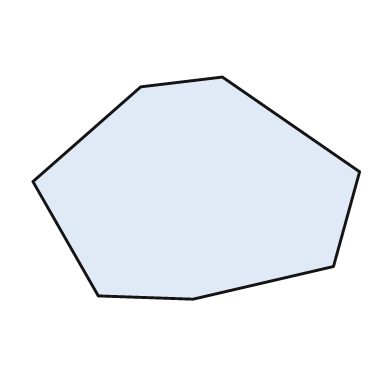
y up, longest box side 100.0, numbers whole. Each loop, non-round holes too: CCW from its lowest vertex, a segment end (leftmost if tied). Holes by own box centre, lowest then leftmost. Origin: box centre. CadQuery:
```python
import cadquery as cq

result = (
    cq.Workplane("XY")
    .moveTo(-1.0, -34.0)
    .lineTo(42.0, -24.0)
    .lineTo(50.0, 5.0)
    .lineTo(8.0, 34.0)
    .lineTo(-17.0, 31.0)
    .lineTo(-50.0, 2.0)
    .lineTo(-30.0, -33.0)
    .close()
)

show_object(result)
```